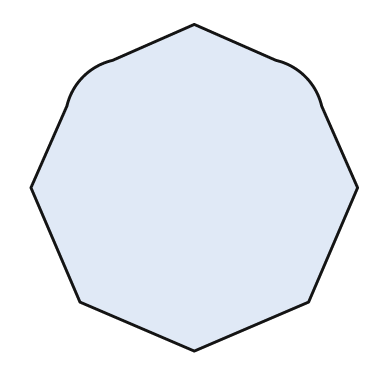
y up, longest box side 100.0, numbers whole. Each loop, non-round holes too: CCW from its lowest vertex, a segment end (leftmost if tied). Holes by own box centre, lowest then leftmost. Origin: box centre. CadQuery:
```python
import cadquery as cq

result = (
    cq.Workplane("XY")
    .moveTo(0.0, -50.0)
    .lineTo(35.0, -35.0)
    .lineTo(50.0, 0.0)
    .lineTo(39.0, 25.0)
    .threePointArc((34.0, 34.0), (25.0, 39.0))
    .lineTo(0.0, 50.0)
    .lineTo(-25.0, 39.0)
    .threePointArc((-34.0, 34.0), (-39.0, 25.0))
    .lineTo(-50.0, 0.0)
    .lineTo(-35.0, -35.0)
    .close()
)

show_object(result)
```